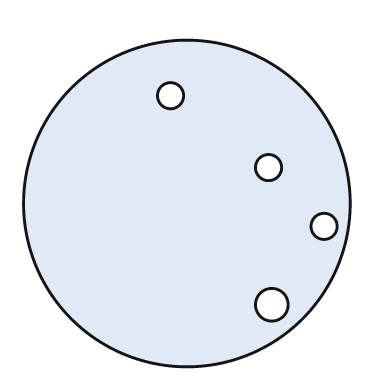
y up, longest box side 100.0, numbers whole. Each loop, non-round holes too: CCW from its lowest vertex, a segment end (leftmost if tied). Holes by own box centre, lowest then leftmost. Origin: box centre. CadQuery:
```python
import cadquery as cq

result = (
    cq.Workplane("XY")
    .moveTo(0.0, 0.0)
    .circle(50.0)
    .moveTo(26.0, -31.0)
    .circle(5.0)
    .moveTo(42.0, -7.0)
    .circle(4.0)
    .moveTo(25.0, 11.0)
    .circle(4.0)
    .moveTo(-5.0, 33.0)
    .circle(4.0)
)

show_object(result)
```